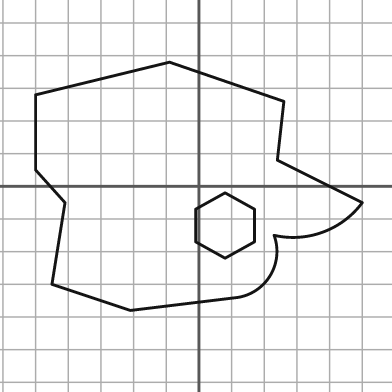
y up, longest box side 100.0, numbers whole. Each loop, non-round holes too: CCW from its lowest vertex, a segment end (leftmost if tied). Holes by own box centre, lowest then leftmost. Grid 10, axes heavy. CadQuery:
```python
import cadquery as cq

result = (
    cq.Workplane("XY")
    .moveTo(-21.0, -38.0)
    .lineTo(12.0, -34.0)
    .threePointArc((22.0, -27.0), (23.0, -15.0))
    .threePointArc((38.0, -14.0), (50.0, -5.0))
    .lineTo(24.0, 8.0)
    .lineTo(26.0, 26.0)
    .lineTo(-9.0, 38.0)
    .lineTo(-50.0, 28.0)
    .lineTo(-50.0, 5.0)
    .lineTo(-41.0, -5.0)
    .lineTo(-45.0, -30.0)
    .close()
    .moveTo(8.0, -22.0)
    .lineTo(17.0, -17.0)
    .lineTo(17.0, -7.0)
    .lineTo(8.0, -2.0)
    .lineTo(-1.0, -7.0)
    .lineTo(-1.0, -17.0)
    .close()
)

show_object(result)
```